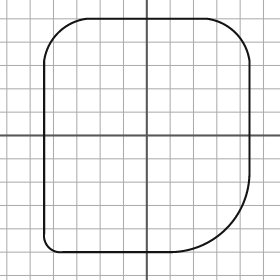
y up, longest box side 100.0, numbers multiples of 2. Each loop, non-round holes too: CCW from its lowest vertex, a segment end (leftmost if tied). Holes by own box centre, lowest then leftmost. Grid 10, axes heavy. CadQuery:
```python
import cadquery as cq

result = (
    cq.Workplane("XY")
    .moveTo(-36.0, -50.0)
    .lineTo(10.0, -50.0)
    .threePointArc((34.0, -40.0), (44.0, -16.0))
    .lineTo(44.0, 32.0)
    .threePointArc((38.0, 44.0), (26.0, 50.0))
    .lineTo(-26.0, 50.0)
    .threePointArc((-38.0, 44.0), (-44.0, 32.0))
    .lineTo(-44.0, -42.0)
    .threePointArc((-42.0, -48.0), (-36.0, -50.0))
    .close()
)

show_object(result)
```